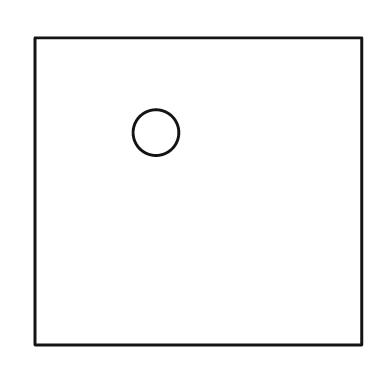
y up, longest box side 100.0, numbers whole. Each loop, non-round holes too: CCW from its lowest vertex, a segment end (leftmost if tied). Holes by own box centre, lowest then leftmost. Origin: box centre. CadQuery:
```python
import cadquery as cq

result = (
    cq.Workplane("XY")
    .moveTo(-50.0, -47.0)
    .lineTo(50.0, -47.0)
    .lineTo(50.0, 47.0)
    .lineTo(-50.0, 47.0)
    .close()
    .moveTo(-13.0, 18.0)
    .circle(7.0)
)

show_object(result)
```